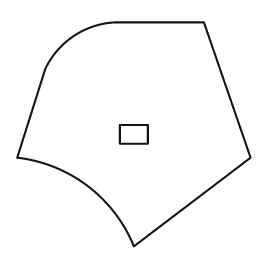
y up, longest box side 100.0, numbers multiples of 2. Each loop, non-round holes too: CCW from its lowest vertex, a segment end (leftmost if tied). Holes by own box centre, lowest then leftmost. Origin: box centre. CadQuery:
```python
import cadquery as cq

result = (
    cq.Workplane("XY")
    .moveTo(0.0, -48.0)
    .lineTo(50.0, -10.0)
    .lineTo(30.0, 48.0)
    .lineTo(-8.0, 48.0)
    .threePointArc((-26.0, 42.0), (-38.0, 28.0))
    .lineTo(-50.0, -10.0)
    .threePointArc((-20.0, -22.0), (0.0, -48.0))
    .close()
    .moveTo(-6.0, -4.0)
    .lineTo(6.0, -4.0)
    .lineTo(6.0, 4.0)
    .lineTo(-6.0, 4.0)
    .close()
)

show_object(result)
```